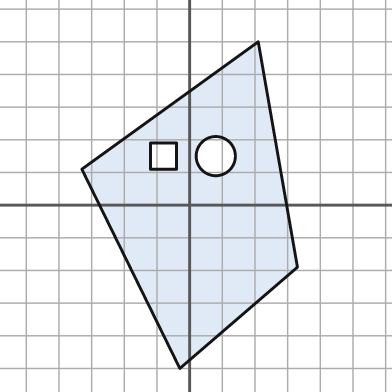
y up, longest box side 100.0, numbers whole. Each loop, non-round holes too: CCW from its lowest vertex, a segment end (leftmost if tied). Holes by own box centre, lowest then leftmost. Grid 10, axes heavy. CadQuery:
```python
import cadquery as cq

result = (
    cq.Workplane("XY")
    .moveTo(-3.0, -50.0)
    .lineTo(33.0, -19.0)
    .lineTo(21.0, 50.0)
    .lineTo(-33.0, 11.0)
    .close()
    .moveTo(-12.0, 11.0)
    .lineTo(-4.0, 11.0)
    .lineTo(-4.0, 19.0)
    .lineTo(-12.0, 19.0)
    .close()
    .moveTo(8.0, 15.0)
    .circle(6.0)
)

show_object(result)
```